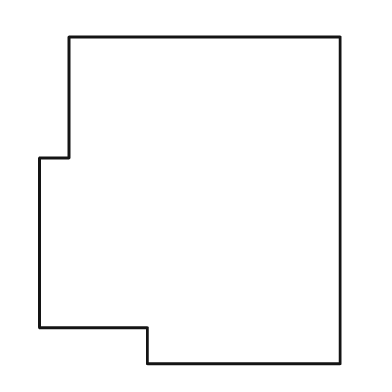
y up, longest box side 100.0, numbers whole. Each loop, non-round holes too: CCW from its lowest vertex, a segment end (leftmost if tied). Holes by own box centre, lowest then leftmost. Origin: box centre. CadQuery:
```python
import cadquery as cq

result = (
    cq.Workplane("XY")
    .moveTo(-13.0, -50.0)
    .lineTo(46.0, -50.0)
    .lineTo(46.0, 50.0)
    .lineTo(-37.0, 50.0)
    .lineTo(-37.0, 13.0)
    .lineTo(-46.0, 13.0)
    .lineTo(-46.0, -39.0)
    .lineTo(-13.0, -39.0)
    .close()
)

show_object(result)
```